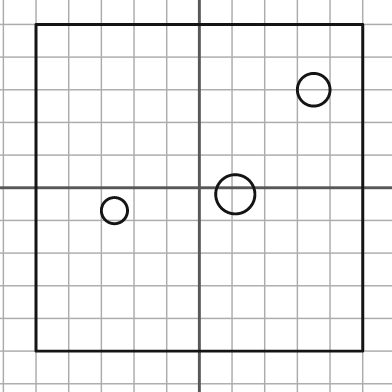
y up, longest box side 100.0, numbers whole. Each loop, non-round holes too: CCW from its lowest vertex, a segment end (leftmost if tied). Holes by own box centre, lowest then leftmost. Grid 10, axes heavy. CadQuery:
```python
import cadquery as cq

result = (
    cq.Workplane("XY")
    .moveTo(-50.0, -50.0)
    .lineTo(50.0, -50.0)
    .lineTo(50.0, 50.0)
    .lineTo(-50.0, 50.0)
    .close()
    .moveTo(-26.0, -7.0)
    .circle(4.0)
    .moveTo(11.0, -2.0)
    .circle(6.0)
    .moveTo(35.0, 30.0)
    .circle(5.0)
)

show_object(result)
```